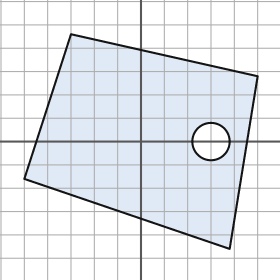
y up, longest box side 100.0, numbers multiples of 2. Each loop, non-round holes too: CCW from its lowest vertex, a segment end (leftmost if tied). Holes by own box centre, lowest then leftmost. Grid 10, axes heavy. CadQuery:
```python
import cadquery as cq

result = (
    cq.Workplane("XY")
    .moveTo(38.0, -46.0)
    .lineTo(50.0, 28.0)
    .lineTo(-30.0, 46.0)
    .lineTo(-50.0, -16.0)
    .close()
    .moveTo(30.0, 0.0)
    .circle(8.0)
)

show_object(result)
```